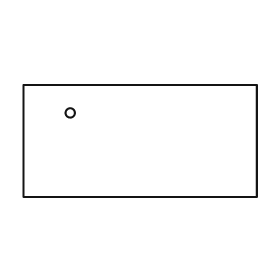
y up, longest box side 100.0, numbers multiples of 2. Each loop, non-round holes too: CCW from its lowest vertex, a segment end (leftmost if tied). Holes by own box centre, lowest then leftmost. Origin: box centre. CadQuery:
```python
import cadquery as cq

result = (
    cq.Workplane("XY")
    .moveTo(-50.0, -24.0)
    .lineTo(50.0, -24.0)
    .lineTo(50.0, 24.0)
    .lineTo(-50.0, 24.0)
    .close()
    .moveTo(-30.0, 12.0)
    .circle(2.0)
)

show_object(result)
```